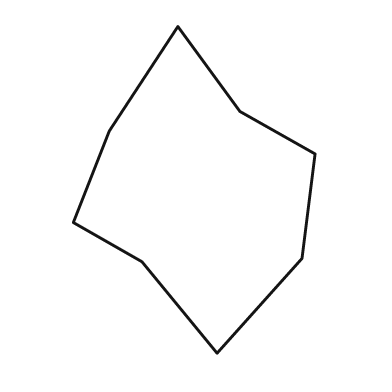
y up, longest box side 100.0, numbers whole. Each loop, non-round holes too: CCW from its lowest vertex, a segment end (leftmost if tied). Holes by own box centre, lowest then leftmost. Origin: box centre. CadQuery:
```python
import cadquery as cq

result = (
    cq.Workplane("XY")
    .moveTo(7.0, -50.0)
    .lineTo(33.0, -21.0)
    .lineTo(37.0, 11.0)
    .lineTo(14.0, 24.0)
    .lineTo(-5.0, 50.0)
    .lineTo(-26.0, 18.0)
    .lineTo(-37.0, -10.0)
    .lineTo(-16.0, -22.0)
    .close()
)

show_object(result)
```